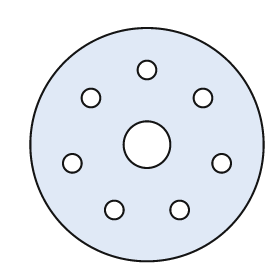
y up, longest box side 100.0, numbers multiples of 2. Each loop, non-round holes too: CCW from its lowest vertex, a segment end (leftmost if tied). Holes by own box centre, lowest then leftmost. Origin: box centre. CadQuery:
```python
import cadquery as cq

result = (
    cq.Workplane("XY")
    .moveTo(0.0, 0.0)
    .circle(50.0)
    .moveTo(-14.0, -28.0)
    .circle(4.0)
    .moveTo(14.0, -28.0)
    .circle(4.0)
    .moveTo(-32.0, -8.0)
    .circle(4.0)
    .moveTo(32.0, -8.0)
    .circle(4.0)
    .moveTo(0.0, 0.0)
    .circle(10.0)
    .moveTo(-24.0, 20.0)
    .circle(4.0)
    .moveTo(24.0, 20.0)
    .circle(4.0)
    .moveTo(0.0, 32.0)
    .circle(4.0)
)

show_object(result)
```